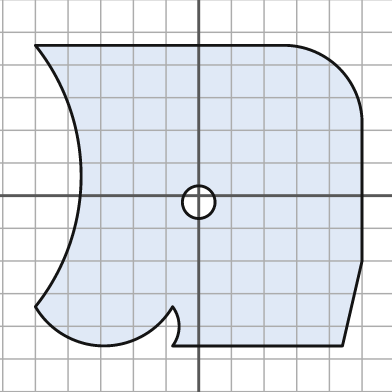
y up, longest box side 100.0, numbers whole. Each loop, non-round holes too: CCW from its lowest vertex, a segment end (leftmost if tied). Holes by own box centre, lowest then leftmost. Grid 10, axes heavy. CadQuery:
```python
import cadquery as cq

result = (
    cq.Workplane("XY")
    .moveTo(-8.0, -46.0)
    .lineTo(44.0, -46.0)
    .lineTo(50.0, -20.0)
    .lineTo(50.0, 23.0)
    .threePointArc((43.0, 39.0), (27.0, 46.0))
    .lineTo(-50.0, 46.0)
    .threePointArc((-36.0, 6.0), (-50.0, -34.0))
    .threePointArc((-29.0, -46.0), (-8.0, -34.0))
    .threePointArc((-6.0, -40.0), (-8.0, -46.0))
    .close()
    .moveTo(0.0, -2.0)
    .circle(5.0)
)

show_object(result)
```